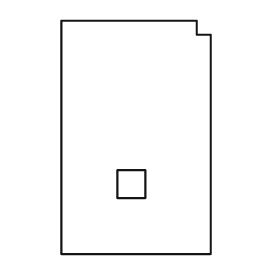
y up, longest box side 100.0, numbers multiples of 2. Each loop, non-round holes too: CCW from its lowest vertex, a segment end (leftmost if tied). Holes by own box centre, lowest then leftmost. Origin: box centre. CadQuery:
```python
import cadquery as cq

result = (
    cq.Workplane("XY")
    .moveTo(-32.0, -50.0)
    .lineTo(32.0, -50.0)
    .lineTo(32.0, 44.0)
    .lineTo(26.0, 44.0)
    .lineTo(26.0, 50.0)
    .lineTo(-32.0, 50.0)
    .close()
    .moveTo(-8.0, -26.0)
    .lineTo(4.0, -26.0)
    .lineTo(4.0, -14.0)
    .lineTo(-8.0, -14.0)
    .close()
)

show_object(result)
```